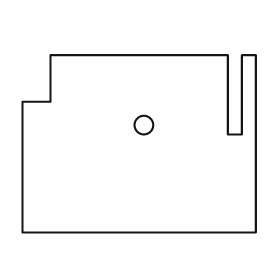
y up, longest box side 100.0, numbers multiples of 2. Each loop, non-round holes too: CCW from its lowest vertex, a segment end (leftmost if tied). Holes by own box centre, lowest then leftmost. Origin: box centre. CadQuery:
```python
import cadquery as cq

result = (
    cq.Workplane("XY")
    .moveTo(-50.0, -38.0)
    .lineTo(50.0, -38.0)
    .lineTo(50.0, 38.0)
    .lineTo(44.0, 38.0)
    .lineTo(44.0, 4.0)
    .lineTo(38.0, 4.0)
    .lineTo(38.0, 38.0)
    .lineTo(-38.0, 38.0)
    .lineTo(-38.0, 18.0)
    .lineTo(-50.0, 18.0)
    .close()
    .moveTo(2.0, 8.0)
    .circle(4.0)
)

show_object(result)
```